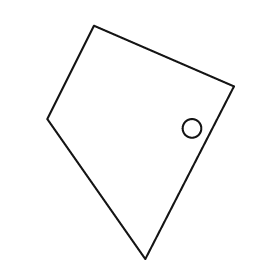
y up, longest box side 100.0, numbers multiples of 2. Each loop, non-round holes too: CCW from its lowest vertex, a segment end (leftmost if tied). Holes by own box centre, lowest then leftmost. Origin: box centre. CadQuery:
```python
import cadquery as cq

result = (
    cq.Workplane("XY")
    .moveTo(2.0, -50.0)
    .lineTo(40.0, 24.0)
    .lineTo(-20.0, 50.0)
    .lineTo(-40.0, 10.0)
    .close()
    .moveTo(22.0, 6.0)
    .circle(4.0)
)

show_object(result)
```